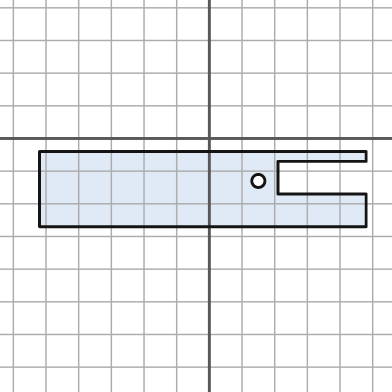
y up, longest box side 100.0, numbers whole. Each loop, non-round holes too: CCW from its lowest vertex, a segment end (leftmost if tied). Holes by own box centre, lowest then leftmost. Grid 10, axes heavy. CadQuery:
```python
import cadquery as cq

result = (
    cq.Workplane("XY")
    .moveTo(-52.0, -27.0)
    .lineTo(48.0, -27.0)
    .lineTo(48.0, -17.0)
    .lineTo(21.0, -17.0)
    .lineTo(21.0, -7.0)
    .lineTo(48.0, -7.0)
    .lineTo(48.0, -4.0)
    .lineTo(-52.0, -4.0)
    .close()
    .moveTo(15.0, -13.0)
    .circle(2.0)
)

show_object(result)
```